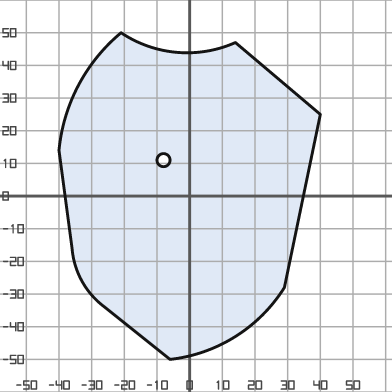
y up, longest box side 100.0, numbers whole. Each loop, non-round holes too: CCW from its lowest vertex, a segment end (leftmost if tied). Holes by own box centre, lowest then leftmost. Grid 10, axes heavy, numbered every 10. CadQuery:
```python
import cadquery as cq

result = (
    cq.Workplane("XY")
    .moveTo(-6.0, -50.0)
    .threePointArc((14.0, -43.0), (29.0, -28.0))
    .lineTo(40.0, 25.0)
    .lineTo(14.0, 47.0)
    .threePointArc((-4.0, 44.0), (-21.0, 50.0))
    .threePointArc((-34.0, 34.0), (-40.0, 14.0))
    .lineTo(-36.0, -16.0)
    .threePointArc((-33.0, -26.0), (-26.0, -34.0))
    .close()
    .moveTo(-8.0, 11.0)
    .circle(2.0)
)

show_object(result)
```